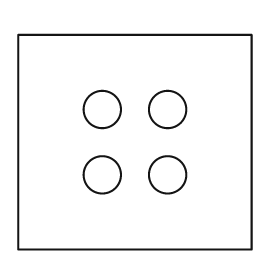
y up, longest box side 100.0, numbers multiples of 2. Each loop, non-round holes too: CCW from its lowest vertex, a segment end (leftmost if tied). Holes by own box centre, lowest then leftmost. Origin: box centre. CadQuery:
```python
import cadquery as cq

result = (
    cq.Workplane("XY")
    .moveTo(-50.0, -46.0)
    .lineTo(50.0, -46.0)
    .lineTo(50.0, 46.0)
    .lineTo(-50.0, 46.0)
    .close()
    .moveTo(-14.0, -14.0)
    .circle(8.0)
    .moveTo(14.0, -14.0)
    .circle(8.0)
    .moveTo(-14.0, 14.0)
    .circle(8.0)
    .moveTo(14.0, 14.0)
    .circle(8.0)
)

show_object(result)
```